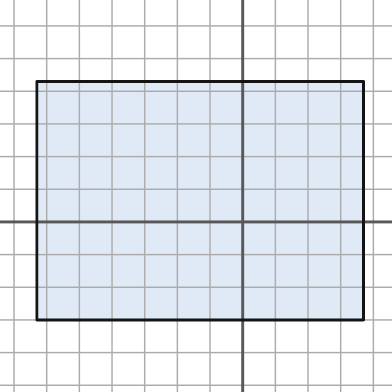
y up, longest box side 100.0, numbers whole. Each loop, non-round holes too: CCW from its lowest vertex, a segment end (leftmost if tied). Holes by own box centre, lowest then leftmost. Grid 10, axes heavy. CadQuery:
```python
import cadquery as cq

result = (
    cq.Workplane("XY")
    .moveTo(-63.0, -30.0)
    .lineTo(37.0, -30.0)
    .lineTo(37.0, 43.0)
    .lineTo(-63.0, 43.0)
    .close()
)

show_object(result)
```